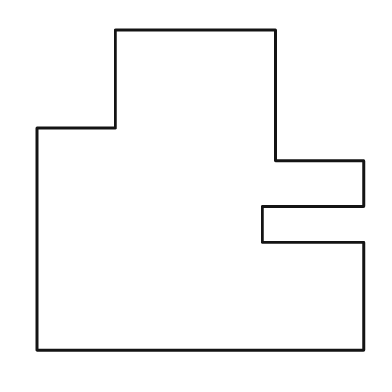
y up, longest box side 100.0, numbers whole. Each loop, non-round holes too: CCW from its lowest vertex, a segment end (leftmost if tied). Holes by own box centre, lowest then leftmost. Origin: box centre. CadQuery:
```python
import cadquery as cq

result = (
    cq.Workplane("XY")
    .moveTo(-50.0, -49.0)
    .lineTo(50.0, -49.0)
    .lineTo(50.0, -16.0)
    .lineTo(19.0, -16.0)
    .lineTo(19.0, -5.0)
    .lineTo(50.0, -5.0)
    .lineTo(50.0, 9.0)
    .lineTo(23.0, 9.0)
    .lineTo(23.0, 49.0)
    .lineTo(-26.0, 49.0)
    .lineTo(-26.0, 19.0)
    .lineTo(-50.0, 19.0)
    .close()
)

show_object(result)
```